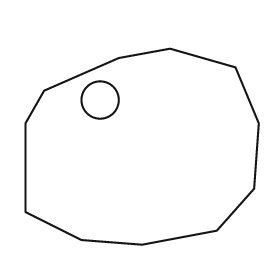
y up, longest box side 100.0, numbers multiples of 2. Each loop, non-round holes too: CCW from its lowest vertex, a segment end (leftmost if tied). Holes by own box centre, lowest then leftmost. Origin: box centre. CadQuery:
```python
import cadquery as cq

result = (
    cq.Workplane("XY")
    .moveTo(0.0, -42.0)
    .lineTo(32.0, -36.0)
    .lineTo(48.0, -18.0)
    .lineTo(50.0, 10.0)
    .lineTo(40.0, 34.0)
    .lineTo(12.0, 42.0)
    .lineTo(-10.0, 38.0)
    .lineTo(-42.0, 24.0)
    .lineTo(-50.0, 10.0)
    .lineTo(-50.0, -28.0)
    .lineTo(-26.0, -40.0)
    .close()
    .moveTo(-18.0, 20.0)
    .circle(8.0)
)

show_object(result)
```